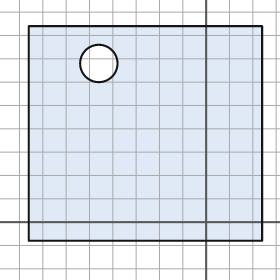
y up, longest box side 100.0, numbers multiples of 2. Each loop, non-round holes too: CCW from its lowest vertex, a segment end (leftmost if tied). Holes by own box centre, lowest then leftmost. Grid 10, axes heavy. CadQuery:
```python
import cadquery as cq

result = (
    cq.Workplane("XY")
    .moveTo(-76.0, -8.0)
    .lineTo(24.0, -8.0)
    .lineTo(24.0, 84.0)
    .lineTo(-76.0, 84.0)
    .close()
    .moveTo(-46.0, 68.0)
    .circle(8.0)
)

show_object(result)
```